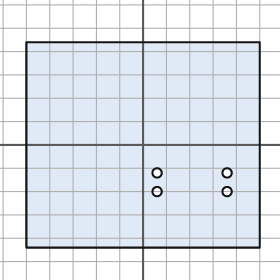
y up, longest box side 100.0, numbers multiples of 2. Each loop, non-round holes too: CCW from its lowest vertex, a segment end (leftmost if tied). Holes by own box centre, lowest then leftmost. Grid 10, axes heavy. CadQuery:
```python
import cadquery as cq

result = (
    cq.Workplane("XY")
    .moveTo(-50.0, -44.0)
    .lineTo(50.0, -44.0)
    .lineTo(50.0, 44.0)
    .lineTo(-50.0, 44.0)
    .close()
    .moveTo(6.0, -20.0)
    .circle(2.0)
    .moveTo(36.0, -20.0)
    .circle(2.0)
    .moveTo(6.0, -12.0)
    .circle(2.0)
    .moveTo(36.0, -12.0)
    .circle(2.0)
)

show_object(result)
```